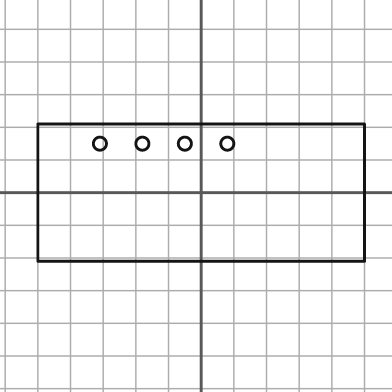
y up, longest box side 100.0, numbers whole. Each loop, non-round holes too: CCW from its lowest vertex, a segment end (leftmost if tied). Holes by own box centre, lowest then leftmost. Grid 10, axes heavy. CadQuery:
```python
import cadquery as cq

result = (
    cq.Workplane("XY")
    .moveTo(-50.0, -21.0)
    .lineTo(50.0, -21.0)
    .lineTo(50.0, 21.0)
    .lineTo(-50.0, 21.0)
    .close()
    .moveTo(-31.0, 15.0)
    .circle(2.0)
    .moveTo(-18.0, 15.0)
    .circle(2.0)
    .moveTo(-5.0, 15.0)
    .circle(2.0)
    .moveTo(8.0, 15.0)
    .circle(2.0)
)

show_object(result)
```